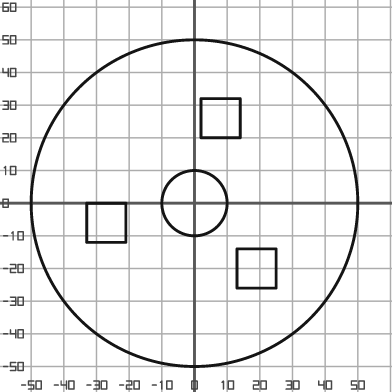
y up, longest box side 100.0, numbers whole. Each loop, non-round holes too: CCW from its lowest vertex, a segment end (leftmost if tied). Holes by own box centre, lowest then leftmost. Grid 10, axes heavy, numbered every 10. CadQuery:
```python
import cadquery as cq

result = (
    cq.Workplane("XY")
    .moveTo(0.0, 0.0)
    .circle(50.0)
    .moveTo(13.0, -26.0)
    .lineTo(25.0, -26.0)
    .lineTo(25.0, -14.0)
    .lineTo(13.0, -14.0)
    .close()
    .moveTo(-33.0, -12.0)
    .lineTo(-21.0, -12.0)
    .lineTo(-21.0, 0.0)
    .lineTo(-33.0, 0.0)
    .close()
    .moveTo(0.0, 0.0)
    .circle(10.0)
    .moveTo(2.0, 20.0)
    .lineTo(14.0, 20.0)
    .lineTo(14.0, 32.0)
    .lineTo(2.0, 32.0)
    .close()
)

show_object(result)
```